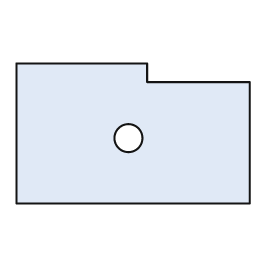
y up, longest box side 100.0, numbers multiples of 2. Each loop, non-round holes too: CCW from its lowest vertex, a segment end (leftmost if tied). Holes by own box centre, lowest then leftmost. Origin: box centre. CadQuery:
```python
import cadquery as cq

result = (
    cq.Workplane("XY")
    .moveTo(-50.0, -30.0)
    .lineTo(50.0, -30.0)
    .lineTo(50.0, 22.0)
    .lineTo(6.0, 22.0)
    .lineTo(6.0, 30.0)
    .lineTo(-50.0, 30.0)
    .close()
    .moveTo(-2.0, -2.0)
    .circle(6.0)
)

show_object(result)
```